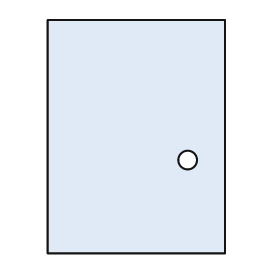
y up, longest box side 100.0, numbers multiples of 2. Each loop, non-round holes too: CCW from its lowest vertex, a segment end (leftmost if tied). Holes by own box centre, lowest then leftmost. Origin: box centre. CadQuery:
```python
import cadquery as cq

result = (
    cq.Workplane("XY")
    .moveTo(-38.0, -50.0)
    .lineTo(38.0, -50.0)
    .lineTo(38.0, 50.0)
    .lineTo(-38.0, 50.0)
    .close()
    .moveTo(22.0, -10.0)
    .circle(4.0)
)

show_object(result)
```